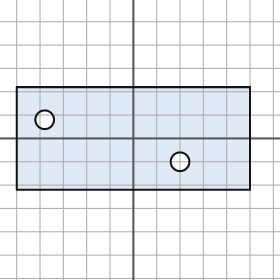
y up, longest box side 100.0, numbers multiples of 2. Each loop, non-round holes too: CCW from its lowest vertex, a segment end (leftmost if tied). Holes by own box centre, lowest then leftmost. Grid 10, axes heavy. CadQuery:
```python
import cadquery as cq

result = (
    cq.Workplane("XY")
    .moveTo(-50.0, -22.0)
    .lineTo(50.0, -22.0)
    .lineTo(50.0, 22.0)
    .lineTo(-50.0, 22.0)
    .close()
    .moveTo(20.0, -10.0)
    .circle(4.0)
    .moveTo(-38.0, 8.0)
    .circle(4.0)
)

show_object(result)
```